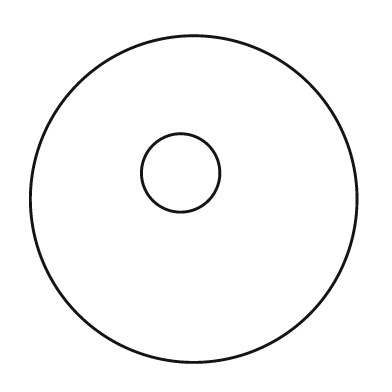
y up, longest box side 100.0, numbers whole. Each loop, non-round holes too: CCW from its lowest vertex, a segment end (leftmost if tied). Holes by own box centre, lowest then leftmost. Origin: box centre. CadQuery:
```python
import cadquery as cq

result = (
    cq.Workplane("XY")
    .moveTo(0.0, 0.0)
    .circle(50.0)
    .moveTo(-4.0, 8.0)
    .circle(12.0)
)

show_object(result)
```